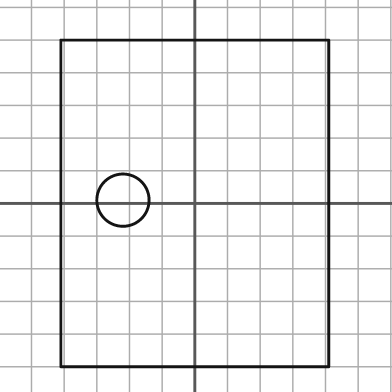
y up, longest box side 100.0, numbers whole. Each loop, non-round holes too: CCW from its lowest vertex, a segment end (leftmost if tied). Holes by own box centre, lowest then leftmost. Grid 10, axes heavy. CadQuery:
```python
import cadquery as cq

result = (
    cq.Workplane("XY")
    .moveTo(-41.0, -50.0)
    .lineTo(41.0, -50.0)
    .lineTo(41.0, 50.0)
    .lineTo(-41.0, 50.0)
    .close()
    .moveTo(-22.0, 1.0)
    .circle(8.0)
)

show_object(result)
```